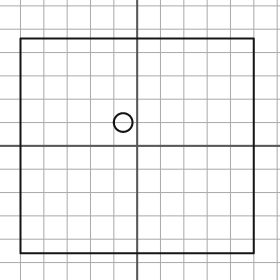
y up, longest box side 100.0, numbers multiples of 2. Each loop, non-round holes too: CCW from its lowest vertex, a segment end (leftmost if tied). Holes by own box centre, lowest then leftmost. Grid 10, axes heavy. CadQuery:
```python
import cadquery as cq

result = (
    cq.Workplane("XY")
    .moveTo(-50.0, -46.0)
    .lineTo(50.0, -46.0)
    .lineTo(50.0, 46.0)
    .lineTo(-50.0, 46.0)
    .close()
    .moveTo(-6.0, 10.0)
    .circle(4.0)
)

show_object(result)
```